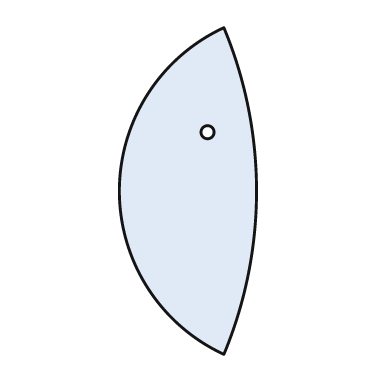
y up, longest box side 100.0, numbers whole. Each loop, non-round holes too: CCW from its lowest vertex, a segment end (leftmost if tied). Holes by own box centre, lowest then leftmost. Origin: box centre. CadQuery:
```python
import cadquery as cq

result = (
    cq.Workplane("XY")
    .moveTo(11.0, -50.0)
    .threePointArc((21.0, 0.0), (11.0, 50.0))
    .threePointArc((-21.0, 0.0), (11.0, -50.0))
    .close()
    .moveTo(6.0, 18.0)
    .circle(2.0)
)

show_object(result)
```